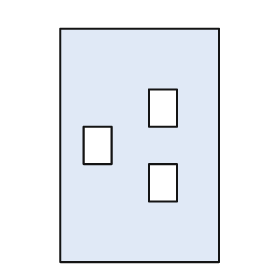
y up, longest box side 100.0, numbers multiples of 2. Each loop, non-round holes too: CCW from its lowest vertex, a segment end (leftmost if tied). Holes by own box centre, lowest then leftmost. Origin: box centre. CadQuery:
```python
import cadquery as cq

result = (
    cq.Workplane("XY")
    .moveTo(-34.0, -50.0)
    .lineTo(34.0, -50.0)
    .lineTo(34.0, 50.0)
    .lineTo(-34.0, 50.0)
    .close()
    .moveTo(4.0, -24.0)
    .lineTo(16.0, -24.0)
    .lineTo(16.0, -8.0)
    .lineTo(4.0, -8.0)
    .close()
    .moveTo(-24.0, -8.0)
    .lineTo(-12.0, -8.0)
    .lineTo(-12.0, 8.0)
    .lineTo(-24.0, 8.0)
    .close()
    .moveTo(4.0, 8.0)
    .lineTo(16.0, 8.0)
    .lineTo(16.0, 24.0)
    .lineTo(4.0, 24.0)
    .close()
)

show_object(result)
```